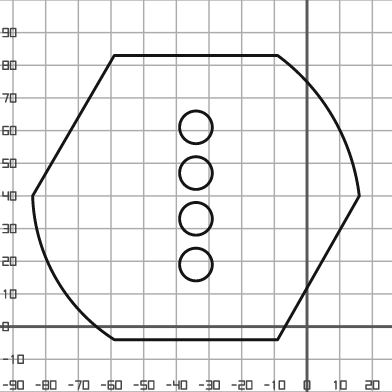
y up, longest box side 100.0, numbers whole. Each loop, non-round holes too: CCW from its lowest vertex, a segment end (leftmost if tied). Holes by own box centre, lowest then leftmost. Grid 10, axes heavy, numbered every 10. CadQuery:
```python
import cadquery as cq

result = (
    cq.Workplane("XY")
    .moveTo(-59.0, -4.0)
    .lineTo(-9.0, -4.0)
    .lineTo(16.0, 40.0)
    .threePointArc((8.0, 64.0), (-9.0, 83.0))
    .lineTo(-59.0, 83.0)
    .lineTo(-84.0, 40.0)
    .threePointArc((-77.0, 15.0), (-59.0, -4.0))
    .close()
    .moveTo(-34.0, 19.0)
    .circle(5.0)
    .moveTo(-34.0, 33.0)
    .circle(5.0)
    .moveTo(-34.0, 47.0)
    .circle(5.0)
    .moveTo(-34.0, 61.0)
    .circle(5.0)
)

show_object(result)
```